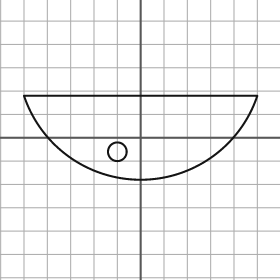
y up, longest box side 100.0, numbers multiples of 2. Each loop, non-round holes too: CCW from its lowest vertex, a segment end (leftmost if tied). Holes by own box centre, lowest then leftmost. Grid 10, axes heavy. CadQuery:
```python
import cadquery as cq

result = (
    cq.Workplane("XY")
    .moveTo(-50.0, 18.0)
    .threePointArc((0.0, -18.0), (50.0, 18.0))
    .close()
    .moveTo(-10.0, -6.0)
    .circle(4.0)
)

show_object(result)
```